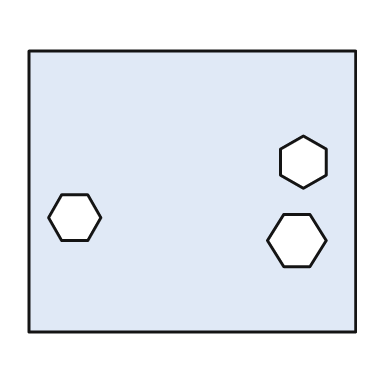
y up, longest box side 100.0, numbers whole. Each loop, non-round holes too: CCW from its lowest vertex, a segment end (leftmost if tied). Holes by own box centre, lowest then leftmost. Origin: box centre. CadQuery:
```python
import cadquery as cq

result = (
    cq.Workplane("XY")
    .moveTo(-50.0, -43.0)
    .lineTo(50.0, -43.0)
    .lineTo(50.0, 43.0)
    .lineTo(-50.0, 43.0)
    .close()
    .moveTo(28.0, -23.0)
    .lineTo(36.0, -23.0)
    .lineTo(41.0, -15.0)
    .lineTo(36.0, -7.0)
    .lineTo(28.0, -7.0)
    .lineTo(23.0, -15.0)
    .close()
    .moveTo(-40.0, -15.0)
    .lineTo(-32.0, -15.0)
    .lineTo(-28.0, -8.0)
    .lineTo(-32.0, -1.0)
    .lineTo(-40.0, -1.0)
    .lineTo(-44.0, -8.0)
    .close()
    .moveTo(34.0, 1.0)
    .lineTo(41.0, 5.0)
    .lineTo(41.0, 13.0)
    .lineTo(34.0, 17.0)
    .lineTo(27.0, 13.0)
    .lineTo(27.0, 5.0)
    .close()
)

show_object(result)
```